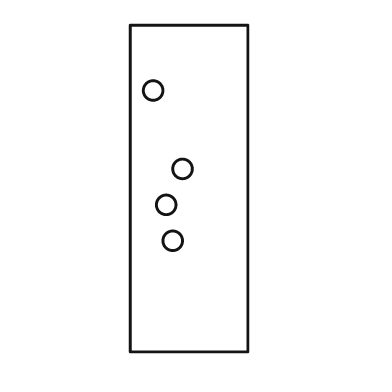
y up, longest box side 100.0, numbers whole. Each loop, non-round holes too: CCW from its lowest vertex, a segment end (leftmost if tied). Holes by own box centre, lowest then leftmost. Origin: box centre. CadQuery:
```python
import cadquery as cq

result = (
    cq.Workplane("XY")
    .moveTo(-18.0, -50.0)
    .lineTo(18.0, -50.0)
    .lineTo(18.0, 50.0)
    .lineTo(-18.0, 50.0)
    .close()
    .moveTo(-5.0, -16.0)
    .circle(3.0)
    .moveTo(-7.0, -5.0)
    .circle(3.0)
    .moveTo(-2.0, 6.0)
    .circle(3.0)
    .moveTo(-11.0, 30.0)
    .circle(3.0)
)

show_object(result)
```